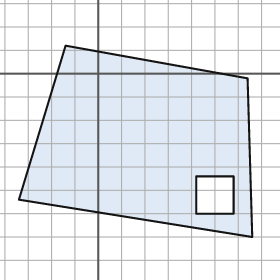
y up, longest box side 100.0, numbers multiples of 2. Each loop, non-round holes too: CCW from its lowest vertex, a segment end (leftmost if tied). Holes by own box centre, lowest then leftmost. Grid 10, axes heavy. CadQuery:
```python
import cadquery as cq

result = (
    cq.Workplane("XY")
    .moveTo(66.0, -70.0)
    .lineTo(64.0, -2.0)
    .lineTo(-14.0, 12.0)
    .lineTo(-34.0, -54.0)
    .close()
    .moveTo(42.0, -60.0)
    .lineTo(58.0, -60.0)
    .lineTo(58.0, -44.0)
    .lineTo(42.0, -44.0)
    .close()
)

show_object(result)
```